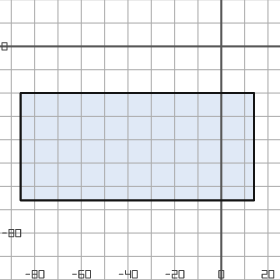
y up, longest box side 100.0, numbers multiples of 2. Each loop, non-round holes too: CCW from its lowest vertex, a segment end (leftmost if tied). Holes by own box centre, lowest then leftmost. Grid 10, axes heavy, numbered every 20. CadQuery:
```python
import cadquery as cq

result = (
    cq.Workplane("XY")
    .moveTo(-86.0, -66.0)
    .lineTo(14.0, -66.0)
    .lineTo(14.0, -20.0)
    .lineTo(-86.0, -20.0)
    .close()
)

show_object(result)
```